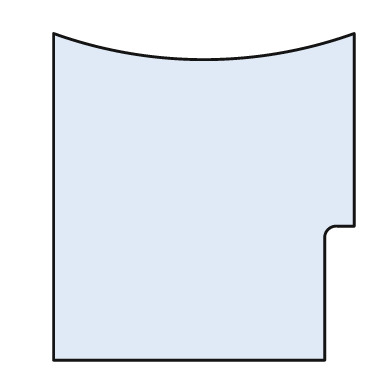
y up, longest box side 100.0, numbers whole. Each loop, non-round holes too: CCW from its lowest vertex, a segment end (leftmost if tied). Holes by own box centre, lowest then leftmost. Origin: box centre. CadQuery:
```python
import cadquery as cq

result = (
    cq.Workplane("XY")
    .moveTo(-46.0, -50.0)
    .lineTo(37.0, -50.0)
    .lineTo(37.0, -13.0)
    .threePointArc((38.0, -10.0), (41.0, -9.0))
    .lineTo(46.0, -9.0)
    .lineTo(46.0, 50.0)
    .threePointArc((0.0, 42.0), (-46.0, 50.0))
    .close()
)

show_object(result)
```